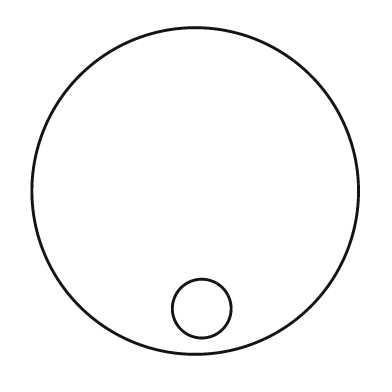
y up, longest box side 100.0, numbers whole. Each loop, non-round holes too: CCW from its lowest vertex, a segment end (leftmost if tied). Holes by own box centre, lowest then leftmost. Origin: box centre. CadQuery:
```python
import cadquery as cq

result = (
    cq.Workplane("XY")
    .moveTo(0.0, 0.0)
    .circle(50.0)
    .moveTo(2.0, -36.0)
    .circle(9.0)
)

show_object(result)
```